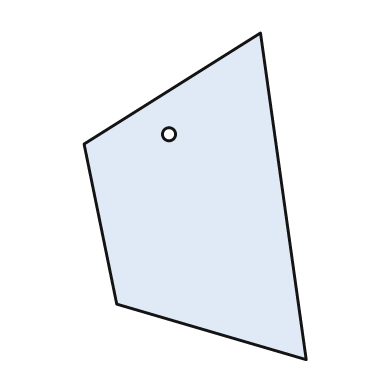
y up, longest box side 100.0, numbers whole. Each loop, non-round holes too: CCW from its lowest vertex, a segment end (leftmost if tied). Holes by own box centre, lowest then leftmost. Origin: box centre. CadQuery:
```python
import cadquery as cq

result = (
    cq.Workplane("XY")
    .moveTo(34.0, -50.0)
    .lineTo(20.0, 50.0)
    .lineTo(-34.0, 16.0)
    .lineTo(-24.0, -33.0)
    .close()
    .moveTo(-8.0, 19.0)
    .circle(2.0)
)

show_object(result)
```